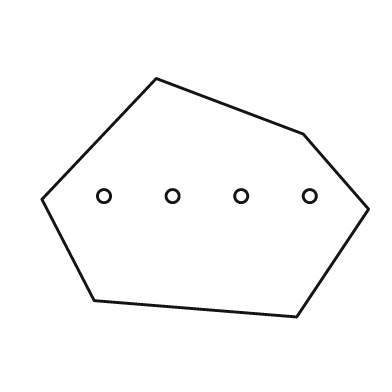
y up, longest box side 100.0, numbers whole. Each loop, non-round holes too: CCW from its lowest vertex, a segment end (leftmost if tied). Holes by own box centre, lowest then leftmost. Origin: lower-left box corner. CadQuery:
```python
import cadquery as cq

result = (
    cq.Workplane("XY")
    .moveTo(78.0, 0.0)
    .lineTo(100.0, 33.0)
    .lineTo(80.0, 56.0)
    .lineTo(35.0, 73.0)
    .lineTo(0.0, 36.0)
    .lineTo(16.0, 5.0)
    .close()
    .moveTo(19.0, 37.0)
    .circle(2.0)
    .moveTo(40.0, 37.0)
    .circle(2.0)
    .moveTo(61.0, 37.0)
    .circle(2.0)
    .moveTo(82.0, 37.0)
    .circle(2.0)
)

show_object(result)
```